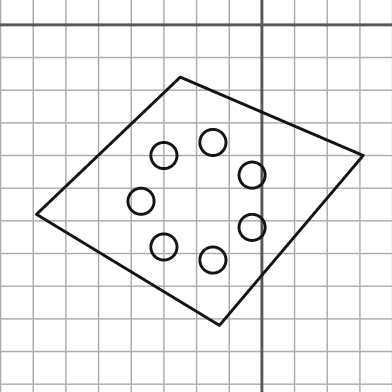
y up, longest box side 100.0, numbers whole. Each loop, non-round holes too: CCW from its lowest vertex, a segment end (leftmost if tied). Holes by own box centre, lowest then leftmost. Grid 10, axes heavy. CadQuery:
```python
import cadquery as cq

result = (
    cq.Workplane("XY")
    .moveTo(-13.0, -92.0)
    .lineTo(31.0, -40.0)
    .lineTo(-25.0, -16.0)
    .lineTo(-69.0, -58.0)
    .close()
    .moveTo(-15.0, -72.0)
    .circle(4.0)
    .moveTo(-30.0, -68.0)
    .circle(4.0)
    .moveTo(-3.0, -62.0)
    .circle(4.0)
    .moveTo(-37.0, -54.0)
    .circle(4.0)
    .moveTo(-3.0, -46.0)
    .circle(4.0)
    .moveTo(-30.0, -40.0)
    .circle(4.0)
    .moveTo(-15.0, -36.0)
    .circle(4.0)
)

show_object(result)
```